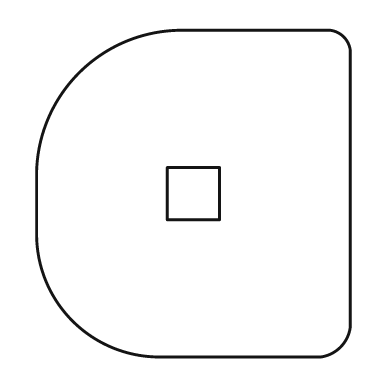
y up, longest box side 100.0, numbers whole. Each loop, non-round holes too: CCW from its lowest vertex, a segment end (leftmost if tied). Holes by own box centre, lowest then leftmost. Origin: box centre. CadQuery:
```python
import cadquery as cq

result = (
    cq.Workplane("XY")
    .moveTo(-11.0, -50.0)
    .lineTo(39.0, -50.0)
    .threePointArc((45.0, -47.0), (48.0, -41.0))
    .lineTo(48.0, 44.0)
    .threePointArc((46.0, 48.0), (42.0, 50.0))
    .lineTo(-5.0, 50.0)
    .threePointArc((-35.0, 37.0), (-48.0, 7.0))
    .lineTo(-48.0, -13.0)
    .threePointArc((-37.0, -39.0), (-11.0, -50.0))
    .close()
    .moveTo(-8.0, -8.0)
    .lineTo(8.0, -8.0)
    .lineTo(8.0, 8.0)
    .lineTo(-8.0, 8.0)
    .close()
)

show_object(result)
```